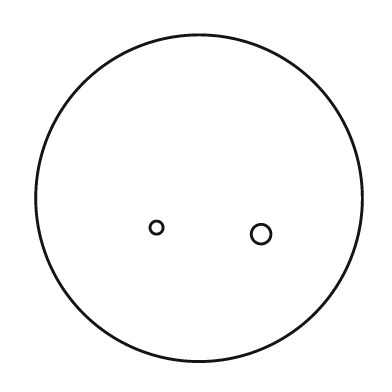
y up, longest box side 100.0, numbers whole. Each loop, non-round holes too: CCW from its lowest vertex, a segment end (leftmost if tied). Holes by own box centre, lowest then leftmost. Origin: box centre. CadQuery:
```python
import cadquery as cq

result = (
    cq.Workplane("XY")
    .moveTo(0.0, 0.0)
    .circle(50.0)
    .moveTo(19.0, -11.0)
    .circle(3.0)
    .moveTo(-13.0, -9.0)
    .circle(2.0)
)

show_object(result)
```